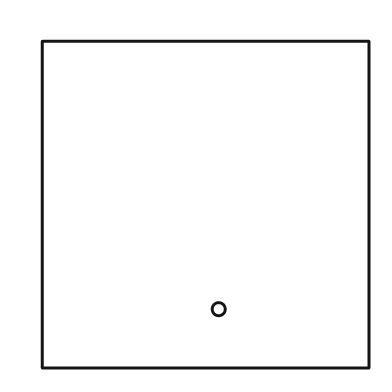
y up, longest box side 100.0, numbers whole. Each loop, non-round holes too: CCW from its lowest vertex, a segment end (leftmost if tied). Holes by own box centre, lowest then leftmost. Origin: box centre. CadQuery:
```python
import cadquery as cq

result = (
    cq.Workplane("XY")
    .moveTo(-50.0, -50.0)
    .lineTo(50.0, -50.0)
    .lineTo(50.0, 50.0)
    .lineTo(-50.0, 50.0)
    .close()
    .moveTo(4.0, -32.0)
    .circle(2.0)
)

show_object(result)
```